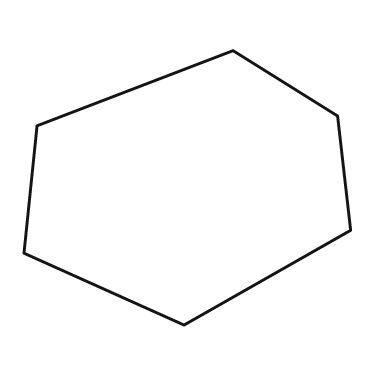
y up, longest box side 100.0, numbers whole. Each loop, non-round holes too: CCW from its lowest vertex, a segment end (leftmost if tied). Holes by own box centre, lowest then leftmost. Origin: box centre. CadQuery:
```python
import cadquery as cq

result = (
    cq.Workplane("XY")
    .moveTo(-1.0, -42.0)
    .lineTo(50.0, -13.0)
    .lineTo(46.0, 22.0)
    .lineTo(14.0, 42.0)
    .lineTo(-46.0, 19.0)
    .lineTo(-50.0, -20.0)
    .close()
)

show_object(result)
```